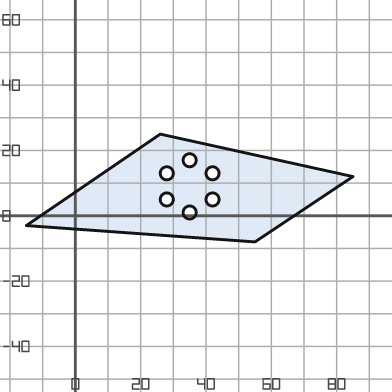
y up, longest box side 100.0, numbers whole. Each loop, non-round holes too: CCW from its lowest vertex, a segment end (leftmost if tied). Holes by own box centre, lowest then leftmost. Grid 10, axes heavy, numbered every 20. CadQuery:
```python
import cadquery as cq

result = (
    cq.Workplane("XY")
    .moveTo(55.0, -8.0)
    .lineTo(85.0, 12.0)
    .lineTo(26.0, 25.0)
    .lineTo(-15.0, -3.0)
    .close()
    .moveTo(35.0, 1.0)
    .circle(2.0)
    .moveTo(28.0, 5.0)
    .circle(2.0)
    .moveTo(42.0, 5.0)
    .circle(2.0)
    .moveTo(28.0, 13.0)
    .circle(2.0)
    .moveTo(42.0, 13.0)
    .circle(2.0)
    .moveTo(35.0, 17.0)
    .circle(2.0)
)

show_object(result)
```